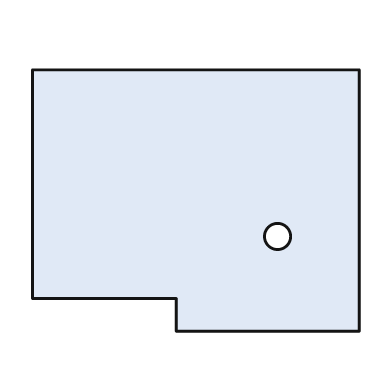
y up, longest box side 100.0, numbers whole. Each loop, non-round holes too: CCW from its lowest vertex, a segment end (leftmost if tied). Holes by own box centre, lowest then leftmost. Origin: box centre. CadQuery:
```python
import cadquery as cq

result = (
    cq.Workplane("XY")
    .moveTo(-6.0, -40.0)
    .lineTo(50.0, -40.0)
    .lineTo(50.0, 40.0)
    .lineTo(-50.0, 40.0)
    .lineTo(-50.0, -30.0)
    .lineTo(-6.0, -30.0)
    .close()
    .moveTo(25.0, -11.0)
    .circle(4.0)
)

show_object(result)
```